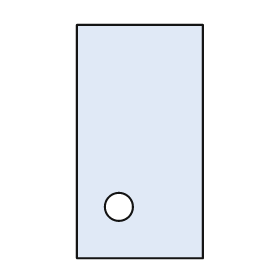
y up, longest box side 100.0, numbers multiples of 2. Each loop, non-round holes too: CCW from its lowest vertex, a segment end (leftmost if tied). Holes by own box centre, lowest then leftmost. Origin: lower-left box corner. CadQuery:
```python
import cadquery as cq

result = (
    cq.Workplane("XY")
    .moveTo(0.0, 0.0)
    .lineTo(54.0, 0.0)
    .lineTo(54.0, 100.0)
    .lineTo(0.0, 100.0)
    .close()
    .moveTo(18.0, 22.0)
    .circle(6.0)
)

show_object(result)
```